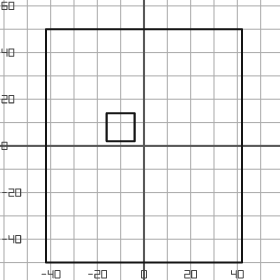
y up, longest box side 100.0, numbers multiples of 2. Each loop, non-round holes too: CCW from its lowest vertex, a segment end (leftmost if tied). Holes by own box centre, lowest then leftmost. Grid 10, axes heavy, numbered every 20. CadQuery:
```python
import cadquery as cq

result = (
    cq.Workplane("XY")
    .moveTo(-42.0, -50.0)
    .lineTo(42.0, -50.0)
    .lineTo(42.0, 50.0)
    .lineTo(-42.0, 50.0)
    .close()
    .moveTo(-16.0, 2.0)
    .lineTo(-4.0, 2.0)
    .lineTo(-4.0, 14.0)
    .lineTo(-16.0, 14.0)
    .close()
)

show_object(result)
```